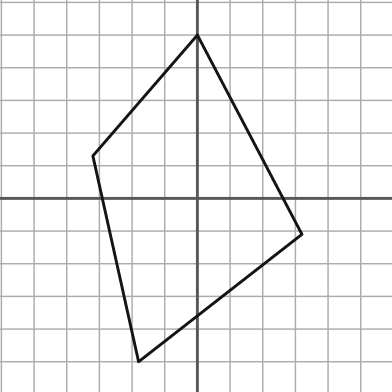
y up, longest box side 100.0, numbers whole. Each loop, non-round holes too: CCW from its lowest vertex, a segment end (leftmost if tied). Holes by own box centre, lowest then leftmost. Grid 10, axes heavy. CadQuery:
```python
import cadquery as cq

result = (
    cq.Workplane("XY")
    .moveTo(-18.0, -50.0)
    .lineTo(32.0, -11.0)
    .lineTo(0.0, 50.0)
    .lineTo(-32.0, 13.0)
    .close()
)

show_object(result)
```